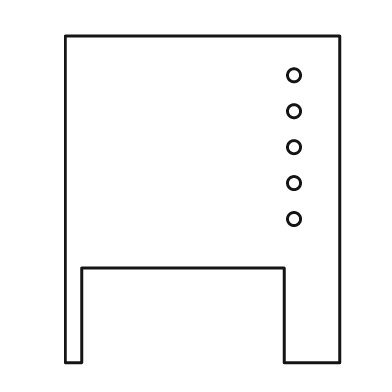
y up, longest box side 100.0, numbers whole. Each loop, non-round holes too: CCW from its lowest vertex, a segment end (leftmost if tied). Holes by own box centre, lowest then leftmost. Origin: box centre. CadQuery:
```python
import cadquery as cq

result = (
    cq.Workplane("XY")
    .moveTo(-42.0, -50.0)
    .lineTo(-37.0, -50.0)
    .lineTo(-37.0, -21.0)
    .lineTo(25.0, -21.0)
    .lineTo(25.0, -50.0)
    .lineTo(42.0, -50.0)
    .lineTo(42.0, 50.0)
    .lineTo(-42.0, 50.0)
    .close()
    .moveTo(28.0, -6.0)
    .circle(2.0)
    .moveTo(28.0, 5.0)
    .circle(2.0)
    .moveTo(28.0, 16.0)
    .circle(2.0)
    .moveTo(28.0, 27.0)
    .circle(2.0)
    .moveTo(28.0, 38.0)
    .circle(2.0)
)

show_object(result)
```